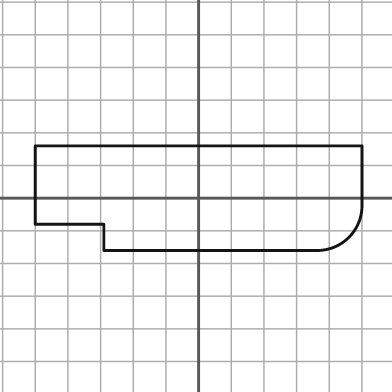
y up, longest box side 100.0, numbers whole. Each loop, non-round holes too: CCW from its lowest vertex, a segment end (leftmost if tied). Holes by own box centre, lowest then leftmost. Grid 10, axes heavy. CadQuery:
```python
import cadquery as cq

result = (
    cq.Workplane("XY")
    .moveTo(-29.0, -16.0)
    .lineTo(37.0, -16.0)
    .threePointArc((46.0, -12.0), (50.0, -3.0))
    .lineTo(50.0, 16.0)
    .lineTo(-50.0, 16.0)
    .lineTo(-50.0, -8.0)
    .lineTo(-29.0, -8.0)
    .close()
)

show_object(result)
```